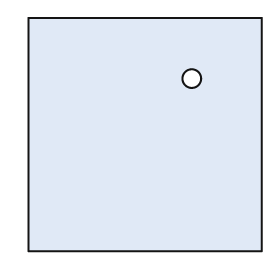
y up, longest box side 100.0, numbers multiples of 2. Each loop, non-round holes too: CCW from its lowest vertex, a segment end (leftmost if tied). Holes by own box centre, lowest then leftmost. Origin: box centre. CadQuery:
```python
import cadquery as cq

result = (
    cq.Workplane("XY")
    .moveTo(-50.0, -50.0)
    .lineTo(50.0, -50.0)
    .lineTo(50.0, 50.0)
    .lineTo(-50.0, 50.0)
    .close()
    .moveTo(20.0, 24.0)
    .circle(4.0)
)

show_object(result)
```